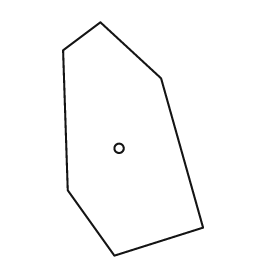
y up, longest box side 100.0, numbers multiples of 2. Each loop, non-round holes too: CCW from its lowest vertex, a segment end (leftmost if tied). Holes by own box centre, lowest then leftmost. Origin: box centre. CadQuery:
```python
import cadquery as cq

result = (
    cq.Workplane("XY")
    .moveTo(-8.0, -50.0)
    .lineTo(30.0, -38.0)
    .lineTo(12.0, 26.0)
    .lineTo(-14.0, 50.0)
    .lineTo(-30.0, 38.0)
    .lineTo(-28.0, -22.0)
    .close()
    .moveTo(-6.0, -4.0)
    .circle(2.0)
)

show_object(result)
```